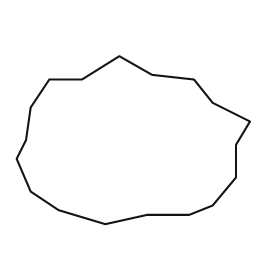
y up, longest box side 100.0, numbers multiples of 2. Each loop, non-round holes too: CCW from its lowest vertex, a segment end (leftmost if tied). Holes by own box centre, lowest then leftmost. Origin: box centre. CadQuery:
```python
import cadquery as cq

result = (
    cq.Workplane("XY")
    .moveTo(-12.0, -36.0)
    .lineTo(6.0, -32.0)
    .lineTo(24.0, -32.0)
    .lineTo(34.0, -28.0)
    .lineTo(44.0, -16.0)
    .lineTo(44.0, -2.0)
    .lineTo(50.0, 8.0)
    .lineTo(34.0, 16.0)
    .lineTo(26.0, 26.0)
    .lineTo(8.0, 28.0)
    .lineTo(-6.0, 36.0)
    .lineTo(-22.0, 26.0)
    .lineTo(-36.0, 26.0)
    .lineTo(-44.0, 14.0)
    .lineTo(-46.0, 0.0)
    .lineTo(-50.0, -8.0)
    .lineTo(-44.0, -22.0)
    .lineTo(-32.0, -30.0)
    .close()
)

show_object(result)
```